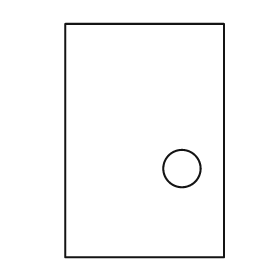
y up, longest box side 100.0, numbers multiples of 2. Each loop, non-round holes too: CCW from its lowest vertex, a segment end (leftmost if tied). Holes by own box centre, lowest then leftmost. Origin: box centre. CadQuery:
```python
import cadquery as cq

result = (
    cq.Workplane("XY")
    .moveTo(-34.0, -50.0)
    .lineTo(34.0, -50.0)
    .lineTo(34.0, 50.0)
    .lineTo(-34.0, 50.0)
    .close()
    .moveTo(16.0, -12.0)
    .circle(8.0)
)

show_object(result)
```